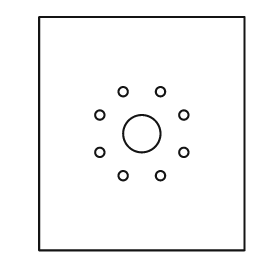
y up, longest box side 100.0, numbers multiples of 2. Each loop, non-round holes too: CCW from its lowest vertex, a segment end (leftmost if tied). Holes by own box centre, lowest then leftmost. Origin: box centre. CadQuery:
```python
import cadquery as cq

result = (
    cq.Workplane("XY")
    .moveTo(-44.0, -50.0)
    .lineTo(44.0, -50.0)
    .lineTo(44.0, 50.0)
    .lineTo(-44.0, 50.0)
    .close()
    .moveTo(-8.0, -18.0)
    .circle(2.0)
    .moveTo(8.0, -18.0)
    .circle(2.0)
    .moveTo(-18.0, -8.0)
    .circle(2.0)
    .moveTo(18.0, -8.0)
    .circle(2.0)
    .moveTo(0.0, 0.0)
    .circle(8.0)
    .moveTo(-18.0, 8.0)
    .circle(2.0)
    .moveTo(18.0, 8.0)
    .circle(2.0)
    .moveTo(-8.0, 18.0)
    .circle(2.0)
    .moveTo(8.0, 18.0)
    .circle(2.0)
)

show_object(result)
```